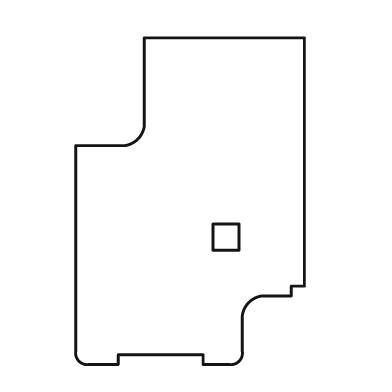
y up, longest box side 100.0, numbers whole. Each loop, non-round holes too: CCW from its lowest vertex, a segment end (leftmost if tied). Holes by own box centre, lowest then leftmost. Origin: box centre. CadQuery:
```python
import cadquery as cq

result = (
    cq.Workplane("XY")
    .moveTo(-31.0, -50.0)
    .lineTo(-22.0, -50.0)
    .lineTo(-22.0, -47.0)
    .lineTo(4.0, -47.0)
    .lineTo(4.0, -50.0)
    .lineTo(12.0, -50.0)
    .threePointArc((15.0, -49.0), (16.0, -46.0))
    .lineTo(16.0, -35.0)
    .threePointArc((18.0, -31.0), (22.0, -29.0))
    .lineTo(31.0, -29.0)
    .lineTo(31.0, -26.0)
    .lineTo(35.0, -26.0)
    .lineTo(35.0, 50.0)
    .lineTo(-14.0, 50.0)
    .lineTo(-14.0, 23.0)
    .threePointArc((-16.0, 19.0), (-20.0, 17.0))
    .lineTo(-35.0, 17.0)
    .lineTo(-35.0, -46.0)
    .threePointArc((-34.0, -49.0), (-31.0, -50.0))
    .close()
    .moveTo(7.0, -15.0)
    .lineTo(15.0, -15.0)
    .lineTo(15.0, -7.0)
    .lineTo(7.0, -7.0)
    .close()
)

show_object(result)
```